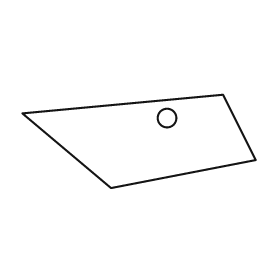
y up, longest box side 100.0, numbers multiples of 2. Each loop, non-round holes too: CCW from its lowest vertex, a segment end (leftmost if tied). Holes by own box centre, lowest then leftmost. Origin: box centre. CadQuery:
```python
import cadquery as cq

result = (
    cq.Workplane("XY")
    .moveTo(-12.0, -20.0)
    .lineTo(50.0, -8.0)
    .lineTo(36.0, 20.0)
    .lineTo(-50.0, 12.0)
    .close()
    .moveTo(12.0, 10.0)
    .circle(4.0)
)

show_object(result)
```